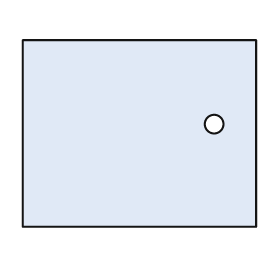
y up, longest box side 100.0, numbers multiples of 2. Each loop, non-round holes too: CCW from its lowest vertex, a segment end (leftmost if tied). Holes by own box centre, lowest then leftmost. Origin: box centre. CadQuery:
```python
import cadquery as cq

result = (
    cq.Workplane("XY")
    .moveTo(-50.0, -40.0)
    .lineTo(50.0, -40.0)
    .lineTo(50.0, 40.0)
    .lineTo(-50.0, 40.0)
    .close()
    .moveTo(32.0, 4.0)
    .circle(4.0)
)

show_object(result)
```